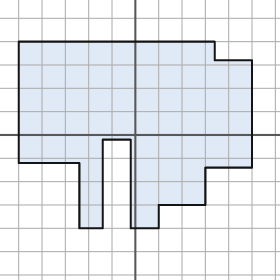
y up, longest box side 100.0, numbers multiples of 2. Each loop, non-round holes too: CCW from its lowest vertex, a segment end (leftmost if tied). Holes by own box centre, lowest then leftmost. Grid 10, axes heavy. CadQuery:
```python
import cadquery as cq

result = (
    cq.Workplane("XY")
    .moveTo(-24.0, -40.0)
    .lineTo(-14.0, -40.0)
    .lineTo(-14.0, -2.0)
    .lineTo(-2.0, -2.0)
    .lineTo(-2.0, -40.0)
    .lineTo(10.0, -40.0)
    .lineTo(10.0, -30.0)
    .lineTo(30.0, -30.0)
    .lineTo(30.0, -14.0)
    .lineTo(50.0, -14.0)
    .lineTo(50.0, 32.0)
    .lineTo(34.0, 32.0)
    .lineTo(34.0, 40.0)
    .lineTo(-50.0, 40.0)
    .lineTo(-50.0, -12.0)
    .lineTo(-24.0, -12.0)
    .close()
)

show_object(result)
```